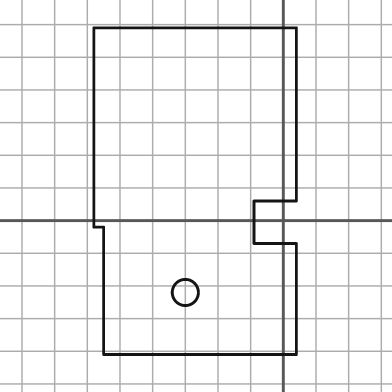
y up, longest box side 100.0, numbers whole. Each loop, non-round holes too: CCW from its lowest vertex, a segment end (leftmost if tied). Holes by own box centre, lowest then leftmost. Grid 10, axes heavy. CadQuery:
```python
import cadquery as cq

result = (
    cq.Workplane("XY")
    .moveTo(-55.0, -41.0)
    .lineTo(4.0, -41.0)
    .lineTo(4.0, -7.0)
    .lineTo(-9.0, -7.0)
    .lineTo(-9.0, 6.0)
    .lineTo(4.0, 6.0)
    .lineTo(4.0, 59.0)
    .lineTo(-58.0, 59.0)
    .lineTo(-58.0, -2.0)
    .lineTo(-55.0, -2.0)
    .close()
    .moveTo(-30.0, -22.0)
    .circle(4.0)
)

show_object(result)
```